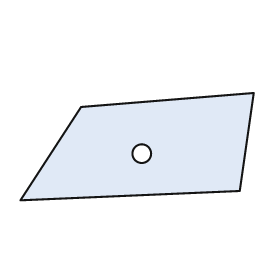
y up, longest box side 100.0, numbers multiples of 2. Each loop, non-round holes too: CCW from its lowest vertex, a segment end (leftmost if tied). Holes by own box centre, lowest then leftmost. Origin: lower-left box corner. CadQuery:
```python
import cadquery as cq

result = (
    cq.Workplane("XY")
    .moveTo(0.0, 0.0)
    .lineTo(94.0, 4.0)
    .lineTo(100.0, 46.0)
    .lineTo(26.0, 40.0)
    .close()
    .moveTo(52.0, 20.0)
    .circle(4.0)
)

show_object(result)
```